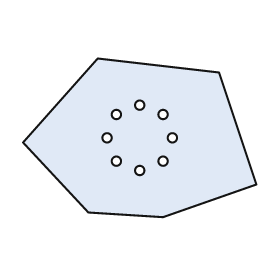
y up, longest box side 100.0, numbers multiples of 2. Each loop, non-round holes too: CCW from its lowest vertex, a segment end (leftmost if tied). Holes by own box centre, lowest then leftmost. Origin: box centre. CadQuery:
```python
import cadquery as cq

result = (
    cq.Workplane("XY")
    .moveTo(10.0, -34.0)
    .lineTo(50.0, -20.0)
    .lineTo(34.0, 28.0)
    .lineTo(-18.0, 34.0)
    .lineTo(-50.0, -2.0)
    .lineTo(-22.0, -32.0)
    .close()
    .moveTo(0.0, -14.0)
    .circle(2.0)
    .moveTo(-10.0, -10.0)
    .circle(2.0)
    .moveTo(10.0, -10.0)
    .circle(2.0)
    .moveTo(-14.0, 0.0)
    .circle(2.0)
    .moveTo(14.0, 0.0)
    .circle(2.0)
    .moveTo(-10.0, 10.0)
    .circle(2.0)
    .moveTo(10.0, 10.0)
    .circle(2.0)
    .moveTo(0.0, 14.0)
    .circle(2.0)
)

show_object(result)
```